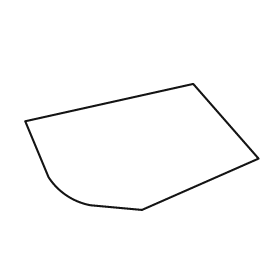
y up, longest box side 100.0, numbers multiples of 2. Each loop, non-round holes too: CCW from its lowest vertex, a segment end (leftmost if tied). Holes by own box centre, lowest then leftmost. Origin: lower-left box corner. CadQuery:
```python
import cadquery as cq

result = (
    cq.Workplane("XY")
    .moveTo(50.0, 0.0)
    .lineTo(100.0, 22.0)
    .lineTo(72.0, 54.0)
    .lineTo(0.0, 38.0)
    .lineTo(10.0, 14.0)
    .threePointArc((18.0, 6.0), (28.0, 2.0))
    .close()
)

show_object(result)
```